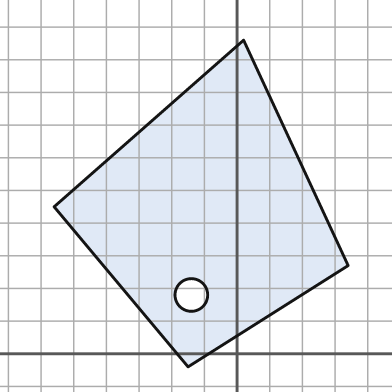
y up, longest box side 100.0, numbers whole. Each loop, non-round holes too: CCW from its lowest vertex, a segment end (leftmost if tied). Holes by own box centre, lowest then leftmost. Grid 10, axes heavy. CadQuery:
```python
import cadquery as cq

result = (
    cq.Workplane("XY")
    .moveTo(-15.0, -4.0)
    .lineTo(34.0, 27.0)
    .lineTo(2.0, 96.0)
    .lineTo(-56.0, 45.0)
    .close()
    .moveTo(-14.0, 18.0)
    .circle(5.0)
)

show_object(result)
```